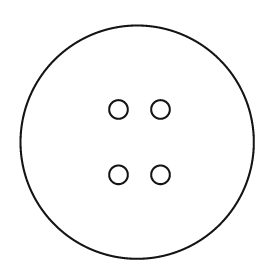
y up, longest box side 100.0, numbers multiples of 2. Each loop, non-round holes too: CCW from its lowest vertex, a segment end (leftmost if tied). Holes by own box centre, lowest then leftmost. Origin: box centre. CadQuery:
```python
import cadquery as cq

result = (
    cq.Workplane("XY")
    .moveTo(0.0, 0.0)
    .circle(50.0)
    .moveTo(-8.0, -14.0)
    .circle(4.0)
    .moveTo(10.0, -14.0)
    .circle(4.0)
    .moveTo(-8.0, 14.0)
    .circle(4.0)
    .moveTo(10.0, 14.0)
    .circle(4.0)
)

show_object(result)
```